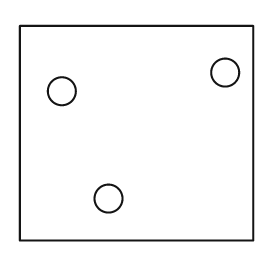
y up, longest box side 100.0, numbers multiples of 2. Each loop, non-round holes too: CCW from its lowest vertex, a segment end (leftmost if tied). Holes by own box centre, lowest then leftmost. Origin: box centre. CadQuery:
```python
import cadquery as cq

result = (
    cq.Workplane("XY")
    .moveTo(-50.0, -46.0)
    .lineTo(50.0, -46.0)
    .lineTo(50.0, 46.0)
    .lineTo(-50.0, 46.0)
    .close()
    .moveTo(-12.0, -28.0)
    .circle(6.0)
    .moveTo(-32.0, 18.0)
    .circle(6.0)
    .moveTo(38.0, 26.0)
    .circle(6.0)
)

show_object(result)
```